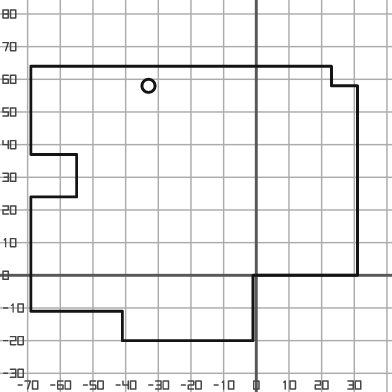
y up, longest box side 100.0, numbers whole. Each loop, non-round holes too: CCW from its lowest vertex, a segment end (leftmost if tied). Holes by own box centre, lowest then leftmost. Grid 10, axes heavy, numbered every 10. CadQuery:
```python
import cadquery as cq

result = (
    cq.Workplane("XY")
    .moveTo(-41.0, -20.0)
    .lineTo(-1.0, -20.0)
    .lineTo(-1.0, 0.0)
    .lineTo(31.0, 0.0)
    .lineTo(31.0, 58.0)
    .lineTo(23.0, 58.0)
    .lineTo(23.0, 64.0)
    .lineTo(-69.0, 64.0)
    .lineTo(-69.0, 37.0)
    .lineTo(-55.0, 37.0)
    .lineTo(-55.0, 24.0)
    .lineTo(-69.0, 24.0)
    .lineTo(-69.0, -11.0)
    .lineTo(-41.0, -11.0)
    .close()
    .moveTo(-33.0, 58.0)
    .circle(2.0)
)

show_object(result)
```